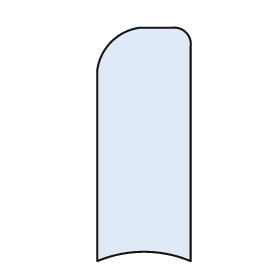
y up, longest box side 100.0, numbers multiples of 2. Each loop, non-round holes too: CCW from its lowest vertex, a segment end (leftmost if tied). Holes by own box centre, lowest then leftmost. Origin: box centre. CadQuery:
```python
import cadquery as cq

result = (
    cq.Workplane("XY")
    .moveTo(-20.0, -50.0)
    .threePointArc((0.0, -46.0), (20.0, -50.0))
    .lineTo(20.0, 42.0)
    .threePointArc((18.0, 48.0), (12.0, 50.0))
    .lineTo(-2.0, 50.0)
    .threePointArc((-14.0, 44.0), (-20.0, 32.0))
    .close()
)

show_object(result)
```